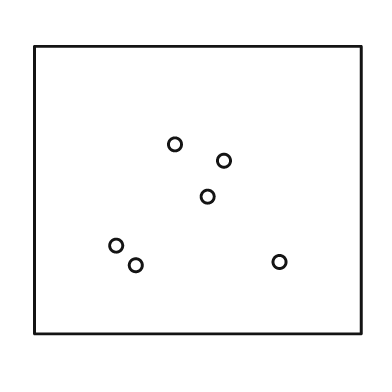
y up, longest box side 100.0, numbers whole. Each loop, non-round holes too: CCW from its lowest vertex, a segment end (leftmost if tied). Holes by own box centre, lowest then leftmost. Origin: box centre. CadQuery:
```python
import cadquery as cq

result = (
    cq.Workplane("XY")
    .moveTo(-50.0, -44.0)
    .lineTo(50.0, -44.0)
    .lineTo(50.0, 44.0)
    .lineTo(-50.0, 44.0)
    .close()
    .moveTo(-19.0, -23.0)
    .circle(2.0)
    .moveTo(25.0, -22.0)
    .circle(2.0)
    .moveTo(-25.0, -17.0)
    .circle(2.0)
    .moveTo(3.0, -2.0)
    .circle(2.0)
    .moveTo(8.0, 9.0)
    .circle(2.0)
    .moveTo(-7.0, 14.0)
    .circle(2.0)
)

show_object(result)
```